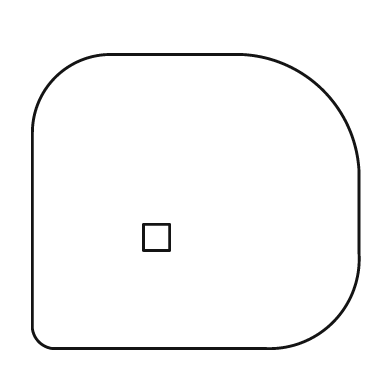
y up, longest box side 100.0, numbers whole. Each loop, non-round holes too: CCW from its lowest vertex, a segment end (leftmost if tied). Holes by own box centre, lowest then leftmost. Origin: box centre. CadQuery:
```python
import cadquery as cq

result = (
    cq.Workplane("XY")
    .moveTo(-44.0, -45.0)
    .lineTo(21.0, -45.0)
    .threePointArc((42.0, -37.0), (50.0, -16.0))
    .lineTo(50.0, 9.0)
    .threePointArc((39.0, 34.0), (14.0, 45.0))
    .lineTo(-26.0, 45.0)
    .threePointArc((-43.0, 38.0), (-50.0, 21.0))
    .lineTo(-50.0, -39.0)
    .threePointArc((-48.0, -43.0), (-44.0, -45.0))
    .close()
    .moveTo(-16.0, -15.0)
    .lineTo(-8.0, -15.0)
    .lineTo(-8.0, -7.0)
    .lineTo(-16.0, -7.0)
    .close()
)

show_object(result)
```